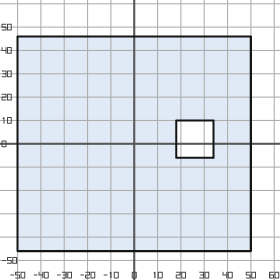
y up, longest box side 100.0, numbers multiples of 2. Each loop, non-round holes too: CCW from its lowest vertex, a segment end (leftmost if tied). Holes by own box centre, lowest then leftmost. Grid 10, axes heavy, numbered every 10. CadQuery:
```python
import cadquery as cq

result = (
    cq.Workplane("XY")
    .moveTo(-50.0, -46.0)
    .lineTo(50.0, -46.0)
    .lineTo(50.0, 46.0)
    .lineTo(-50.0, 46.0)
    .close()
    .moveTo(18.0, -6.0)
    .lineTo(34.0, -6.0)
    .lineTo(34.0, 10.0)
    .lineTo(18.0, 10.0)
    .close()
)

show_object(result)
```